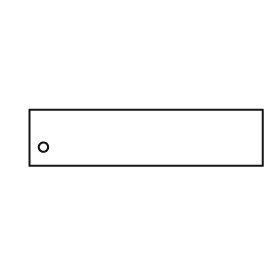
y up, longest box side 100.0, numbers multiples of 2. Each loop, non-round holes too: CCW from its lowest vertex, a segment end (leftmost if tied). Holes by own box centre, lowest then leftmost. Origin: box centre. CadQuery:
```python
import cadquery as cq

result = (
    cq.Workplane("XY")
    .moveTo(-50.0, -12.0)
    .lineTo(50.0, -12.0)
    .lineTo(50.0, 12.0)
    .lineTo(-50.0, 12.0)
    .close()
    .moveTo(-44.0, -4.0)
    .circle(2.0)
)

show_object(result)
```